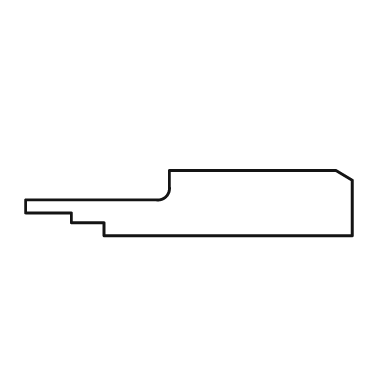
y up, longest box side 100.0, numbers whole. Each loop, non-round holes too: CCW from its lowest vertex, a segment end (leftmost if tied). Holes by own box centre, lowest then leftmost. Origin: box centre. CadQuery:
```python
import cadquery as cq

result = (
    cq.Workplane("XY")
    .moveTo(-26.0, -10.0)
    .lineTo(50.0, -10.0)
    .lineTo(50.0, 7.0)
    .lineTo(45.0, 10.0)
    .lineTo(-6.0, 10.0)
    .lineTo(-6.0, 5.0)
    .threePointArc((-7.0, 2.0), (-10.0, 1.0))
    .lineTo(-50.0, 1.0)
    .lineTo(-50.0, -3.0)
    .lineTo(-36.0, -3.0)
    .lineTo(-36.0, -6.0)
    .lineTo(-26.0, -6.0)
    .close()
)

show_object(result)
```